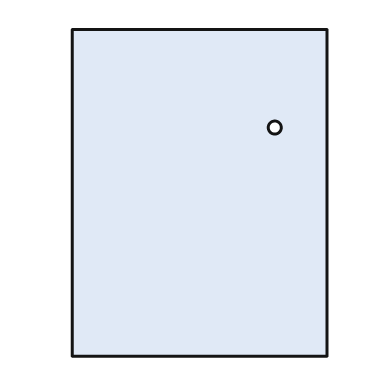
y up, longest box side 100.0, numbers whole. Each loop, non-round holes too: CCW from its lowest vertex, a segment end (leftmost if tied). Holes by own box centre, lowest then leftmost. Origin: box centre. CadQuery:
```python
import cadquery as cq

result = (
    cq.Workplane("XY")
    .moveTo(-39.0, -50.0)
    .lineTo(39.0, -50.0)
    .lineTo(39.0, 50.0)
    .lineTo(-39.0, 50.0)
    .close()
    .moveTo(23.0, 20.0)
    .circle(2.0)
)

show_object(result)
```